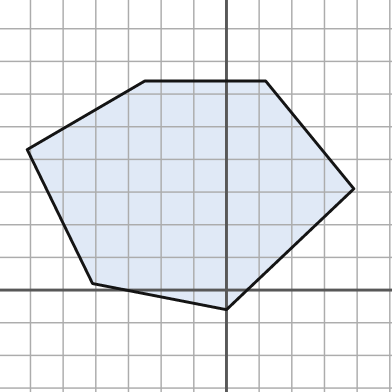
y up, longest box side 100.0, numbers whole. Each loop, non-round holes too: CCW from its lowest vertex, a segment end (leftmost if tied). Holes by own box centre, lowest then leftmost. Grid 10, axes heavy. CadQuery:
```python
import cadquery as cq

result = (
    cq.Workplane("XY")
    .moveTo(0.0, -6.0)
    .lineTo(39.0, 31.0)
    .lineTo(12.0, 64.0)
    .lineTo(-25.0, 64.0)
    .lineTo(-61.0, 43.0)
    .lineTo(-41.0, 2.0)
    .close()
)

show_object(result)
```